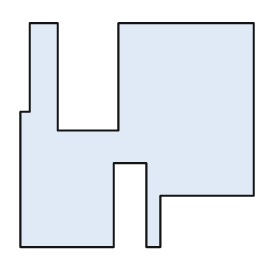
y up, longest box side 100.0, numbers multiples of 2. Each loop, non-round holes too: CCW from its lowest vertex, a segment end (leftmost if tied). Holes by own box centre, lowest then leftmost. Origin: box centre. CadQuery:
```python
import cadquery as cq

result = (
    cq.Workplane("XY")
    .moveTo(-50.0, -48.0)
    .lineTo(-10.0, -48.0)
    .lineTo(-10.0, -12.0)
    .lineTo(4.0, -12.0)
    .lineTo(4.0, -48.0)
    .lineTo(10.0, -48.0)
    .lineTo(10.0, -26.0)
    .lineTo(50.0, -26.0)
    .lineTo(50.0, 48.0)
    .lineTo(-8.0, 48.0)
    .lineTo(-8.0, 2.0)
    .lineTo(-34.0, 2.0)
    .lineTo(-34.0, 48.0)
    .lineTo(-46.0, 48.0)
    .lineTo(-46.0, 10.0)
    .lineTo(-50.0, 10.0)
    .close()
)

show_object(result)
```